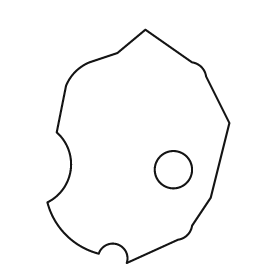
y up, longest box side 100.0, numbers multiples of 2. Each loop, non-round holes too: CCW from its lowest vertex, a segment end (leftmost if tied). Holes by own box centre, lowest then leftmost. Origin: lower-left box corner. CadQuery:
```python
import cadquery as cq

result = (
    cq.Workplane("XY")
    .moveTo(34.0, 0.0)
    .lineTo(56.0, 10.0)
    .threePointArc((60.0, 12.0), (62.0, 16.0))
    .lineTo(70.0, 28.0)
    .lineTo(78.0, 60.0)
    .lineTo(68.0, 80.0)
    .threePointArc((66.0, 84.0), (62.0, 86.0))
    .lineTo(42.0, 100.0)
    .lineTo(30.0, 90.0)
    .lineTo(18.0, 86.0)
    .threePointArc((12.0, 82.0), (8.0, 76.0))
    .lineTo(4.0, 56.0)
    .threePointArc((10.0, 40.0), (0.0, 26.0))
    .threePointArc((8.0, 12.0), (22.0, 4.0))
    .threePointArc((30.0, 8.0), (34.0, 0.0))
    .close()
    .moveTo(54.0, 40.0)
    .circle(8.0)
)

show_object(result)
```